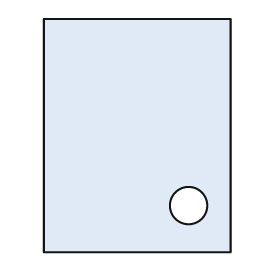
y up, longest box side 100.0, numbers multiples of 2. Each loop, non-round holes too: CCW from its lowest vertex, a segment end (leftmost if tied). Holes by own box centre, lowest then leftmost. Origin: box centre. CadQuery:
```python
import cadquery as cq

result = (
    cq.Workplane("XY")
    .moveTo(-40.0, -50.0)
    .lineTo(40.0, -50.0)
    .lineTo(40.0, 50.0)
    .lineTo(-40.0, 50.0)
    .close()
    .moveTo(22.0, -30.0)
    .circle(8.0)
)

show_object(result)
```